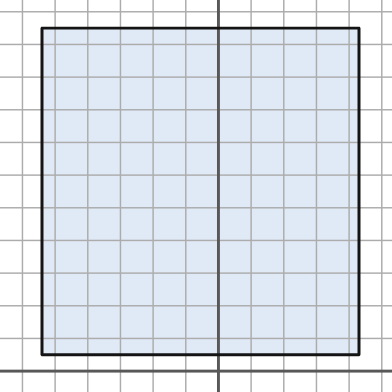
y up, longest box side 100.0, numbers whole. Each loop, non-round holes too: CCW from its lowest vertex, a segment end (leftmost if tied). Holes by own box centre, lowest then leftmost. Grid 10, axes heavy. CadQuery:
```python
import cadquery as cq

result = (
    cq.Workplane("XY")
    .moveTo(-54.0, 5.0)
    .lineTo(43.0, 5.0)
    .lineTo(43.0, 105.0)
    .lineTo(-54.0, 105.0)
    .close()
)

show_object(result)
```